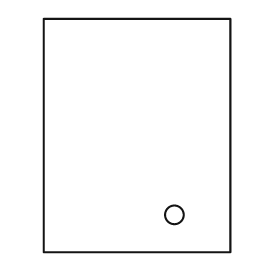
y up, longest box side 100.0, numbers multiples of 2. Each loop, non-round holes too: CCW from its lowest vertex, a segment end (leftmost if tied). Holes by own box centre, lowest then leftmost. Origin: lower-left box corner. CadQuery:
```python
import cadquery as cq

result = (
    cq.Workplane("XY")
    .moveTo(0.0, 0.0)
    .lineTo(80.0, 0.0)
    .lineTo(80.0, 100.0)
    .lineTo(0.0, 100.0)
    .close()
    .moveTo(56.0, 16.0)
    .circle(4.0)
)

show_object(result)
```